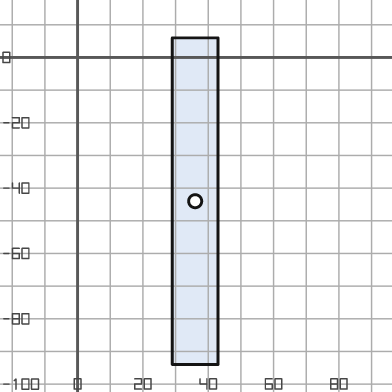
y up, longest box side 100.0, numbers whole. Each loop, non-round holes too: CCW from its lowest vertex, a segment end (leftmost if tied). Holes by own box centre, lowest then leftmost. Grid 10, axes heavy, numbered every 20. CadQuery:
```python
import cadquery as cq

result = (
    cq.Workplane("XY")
    .moveTo(29.0, -94.0)
    .lineTo(43.0, -94.0)
    .lineTo(43.0, 6.0)
    .lineTo(29.0, 6.0)
    .close()
    .moveTo(36.0, -44.0)
    .circle(2.0)
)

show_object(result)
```